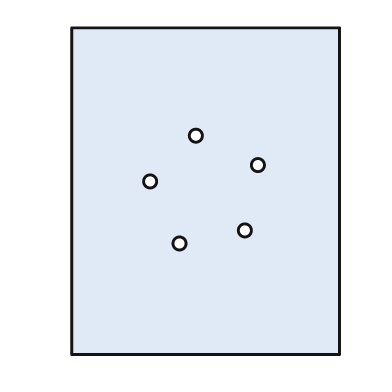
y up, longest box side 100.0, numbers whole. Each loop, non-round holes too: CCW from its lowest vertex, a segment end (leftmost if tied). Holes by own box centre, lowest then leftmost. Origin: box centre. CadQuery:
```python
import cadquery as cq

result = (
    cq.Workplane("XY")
    .moveTo(-41.0, -50.0)
    .lineTo(41.0, -50.0)
    .lineTo(41.0, 50.0)
    .lineTo(-41.0, 50.0)
    .close()
    .moveTo(-8.0, -16.0)
    .circle(2.0)
    .moveTo(12.0, -12.0)
    .circle(2.0)
    .moveTo(-17.0, 3.0)
    .circle(2.0)
    .moveTo(16.0, 8.0)
    .circle(2.0)
    .moveTo(-3.0, 17.0)
    .circle(2.0)
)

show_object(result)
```